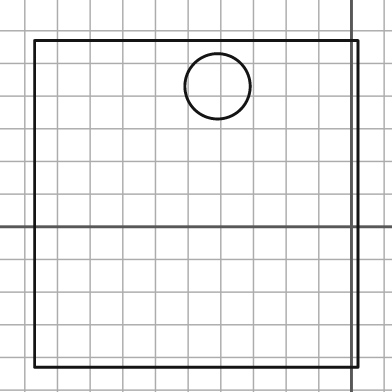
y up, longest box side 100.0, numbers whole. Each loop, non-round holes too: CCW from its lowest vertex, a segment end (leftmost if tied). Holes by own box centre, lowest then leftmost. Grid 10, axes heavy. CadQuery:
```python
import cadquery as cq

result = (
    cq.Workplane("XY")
    .moveTo(-97.0, -43.0)
    .lineTo(2.0, -43.0)
    .lineTo(2.0, 57.0)
    .lineTo(-97.0, 57.0)
    .close()
    .moveTo(-41.0, 43.0)
    .circle(10.0)
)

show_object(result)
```